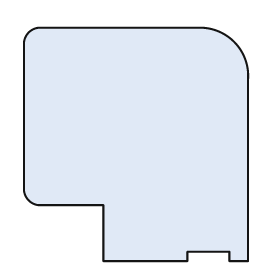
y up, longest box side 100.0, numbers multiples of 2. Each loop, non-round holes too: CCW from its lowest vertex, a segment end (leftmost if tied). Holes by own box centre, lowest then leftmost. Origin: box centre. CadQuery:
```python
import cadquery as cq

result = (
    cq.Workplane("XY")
    .moveTo(-14.0, -50.0)
    .lineTo(22.0, -50.0)
    .lineTo(22.0, -46.0)
    .lineTo(40.0, -46.0)
    .lineTo(40.0, -50.0)
    .lineTo(48.0, -50.0)
    .lineTo(48.0, 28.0)
    .threePointArc((42.0, 44.0), (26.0, 50.0))
    .lineTo(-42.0, 50.0)
    .threePointArc((-46.0, 48.0), (-48.0, 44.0))
    .lineTo(-48.0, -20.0)
    .threePointArc((-46.0, -24.0), (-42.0, -26.0))
    .lineTo(-14.0, -26.0)
    .close()
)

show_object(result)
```